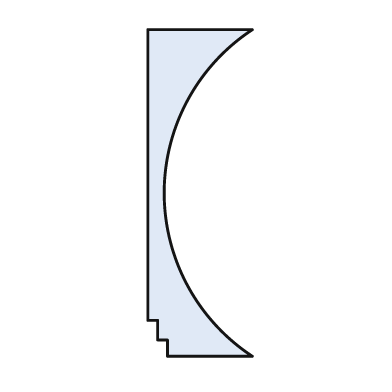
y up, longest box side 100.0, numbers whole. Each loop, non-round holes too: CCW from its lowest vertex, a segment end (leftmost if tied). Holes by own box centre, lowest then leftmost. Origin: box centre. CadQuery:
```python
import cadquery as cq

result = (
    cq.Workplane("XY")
    .moveTo(-10.0, -50.0)
    .lineTo(16.0, -50.0)
    .threePointArc((-11.0, 0.0), (16.0, 50.0))
    .lineTo(-16.0, 50.0)
    .lineTo(-16.0, -39.0)
    .lineTo(-13.0, -39.0)
    .lineTo(-13.0, -45.0)
    .lineTo(-10.0, -45.0)
    .close()
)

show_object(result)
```